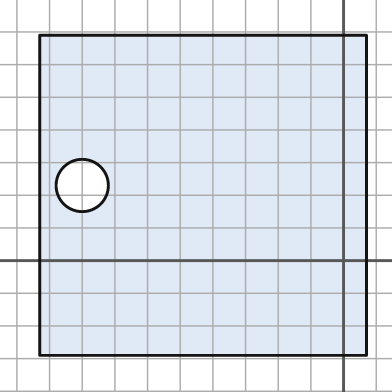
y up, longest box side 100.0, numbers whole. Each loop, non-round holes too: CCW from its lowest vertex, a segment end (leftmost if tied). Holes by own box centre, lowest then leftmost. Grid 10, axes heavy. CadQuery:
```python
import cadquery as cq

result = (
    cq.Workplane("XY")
    .moveTo(-93.0, -29.0)
    .lineTo(7.0, -29.0)
    .lineTo(7.0, 69.0)
    .lineTo(-93.0, 69.0)
    .close()
    .moveTo(-80.0, 23.0)
    .circle(8.0)
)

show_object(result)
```